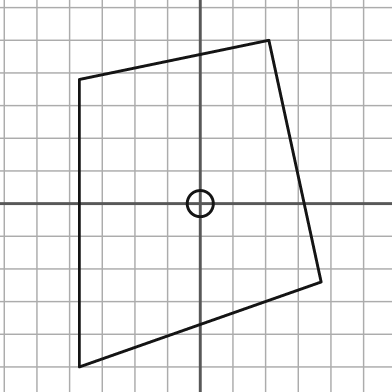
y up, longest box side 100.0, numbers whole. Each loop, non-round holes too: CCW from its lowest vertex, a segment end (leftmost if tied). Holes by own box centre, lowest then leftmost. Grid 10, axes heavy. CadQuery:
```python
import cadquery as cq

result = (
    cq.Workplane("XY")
    .moveTo(-37.0, -50.0)
    .lineTo(37.0, -24.0)
    .lineTo(21.0, 50.0)
    .lineTo(-37.0, 38.0)
    .close()
    .moveTo(0.0, 0.0)
    .circle(4.0)
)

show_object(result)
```